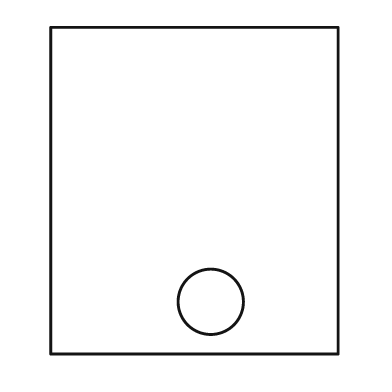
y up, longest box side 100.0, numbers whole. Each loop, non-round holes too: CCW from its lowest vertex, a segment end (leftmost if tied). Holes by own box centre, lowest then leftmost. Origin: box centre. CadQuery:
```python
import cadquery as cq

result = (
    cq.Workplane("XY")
    .moveTo(-44.0, -50.0)
    .lineTo(44.0, -50.0)
    .lineTo(44.0, 50.0)
    .lineTo(-44.0, 50.0)
    .close()
    .moveTo(5.0, -34.0)
    .circle(10.0)
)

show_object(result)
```